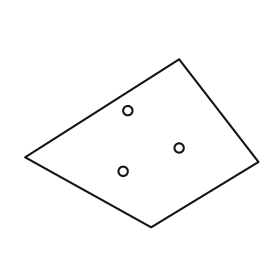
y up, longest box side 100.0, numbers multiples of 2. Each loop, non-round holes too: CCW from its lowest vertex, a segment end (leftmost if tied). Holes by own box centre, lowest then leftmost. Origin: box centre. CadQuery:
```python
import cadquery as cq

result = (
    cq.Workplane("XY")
    .moveTo(4.0, -36.0)
    .lineTo(50.0, -8.0)
    .lineTo(16.0, 36.0)
    .lineTo(-50.0, -6.0)
    .close()
    .moveTo(-8.0, -12.0)
    .circle(2.0)
    .moveTo(16.0, -2.0)
    .circle(2.0)
    .moveTo(-6.0, 14.0)
    .circle(2.0)
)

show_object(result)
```